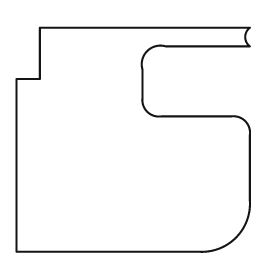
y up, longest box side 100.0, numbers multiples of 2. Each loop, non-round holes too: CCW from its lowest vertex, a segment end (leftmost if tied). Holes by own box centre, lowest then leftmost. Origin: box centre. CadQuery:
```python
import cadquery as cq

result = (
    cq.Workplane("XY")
    .moveTo(-50.0, -48.0)
    .lineTo(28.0, -48.0)
    .threePointArc((44.0, -42.0), (50.0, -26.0))
    .lineTo(50.0, 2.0)
    .threePointArc((48.0, 8.0), (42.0, 10.0))
    .lineTo(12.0, 10.0)
    .threePointArc((6.0, 12.0), (4.0, 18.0))
    .lineTo(4.0, 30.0)
    .threePointArc((6.0, 38.0), (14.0, 40.0))
    .lineTo(50.0, 40.0)
    .threePointArc((48.0, 44.0), (50.0, 48.0))
    .lineTo(-40.0, 48.0)
    .lineTo(-40.0, 26.0)
    .lineTo(-50.0, 26.0)
    .close()
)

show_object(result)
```